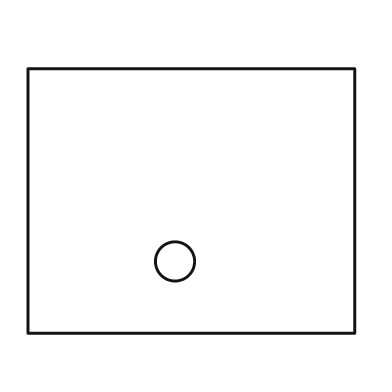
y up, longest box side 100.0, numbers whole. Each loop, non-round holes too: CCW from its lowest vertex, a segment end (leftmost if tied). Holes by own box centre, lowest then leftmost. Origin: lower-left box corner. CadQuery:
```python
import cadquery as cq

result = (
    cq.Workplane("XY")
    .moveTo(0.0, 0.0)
    .lineTo(100.0, 0.0)
    .lineTo(100.0, 81.0)
    .lineTo(0.0, 81.0)
    .close()
    .moveTo(45.0, 22.0)
    .circle(6.0)
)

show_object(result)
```